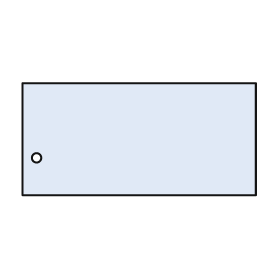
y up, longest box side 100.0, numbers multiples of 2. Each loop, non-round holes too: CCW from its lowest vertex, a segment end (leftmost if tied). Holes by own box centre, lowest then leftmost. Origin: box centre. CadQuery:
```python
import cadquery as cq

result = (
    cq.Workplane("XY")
    .moveTo(-50.0, -24.0)
    .lineTo(50.0, -24.0)
    .lineTo(50.0, 24.0)
    .lineTo(-50.0, 24.0)
    .close()
    .moveTo(-44.0, -8.0)
    .circle(2.0)
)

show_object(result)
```